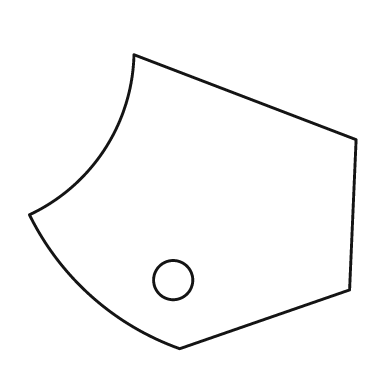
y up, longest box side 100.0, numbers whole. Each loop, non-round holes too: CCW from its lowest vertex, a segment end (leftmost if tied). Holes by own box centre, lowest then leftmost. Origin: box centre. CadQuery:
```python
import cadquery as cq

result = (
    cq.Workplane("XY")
    .moveTo(-4.0, -45.0)
    .lineTo(48.0, -27.0)
    .lineTo(50.0, 19.0)
    .lineTo(-18.0, 45.0)
    .threePointArc((-27.0, 16.0), (-50.0, -4.0))
    .threePointArc((-31.0, -29.0), (-4.0, -45.0))
    .close()
    .moveTo(-6.0, -24.0)
    .circle(6.0)
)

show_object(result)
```